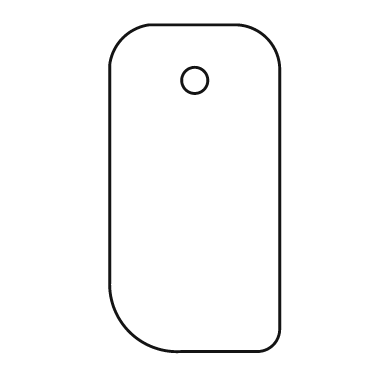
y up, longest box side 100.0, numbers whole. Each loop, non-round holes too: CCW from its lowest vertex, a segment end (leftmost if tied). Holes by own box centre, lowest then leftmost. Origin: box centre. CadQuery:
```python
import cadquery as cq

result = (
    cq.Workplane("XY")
    .moveTo(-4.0, -50.0)
    .lineTo(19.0, -50.0)
    .threePointArc((24.0, -48.0), (26.0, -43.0))
    .lineTo(26.0, 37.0)
    .threePointArc((22.0, 46.0), (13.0, 50.0))
    .lineTo(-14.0, 50.0)
    .threePointArc((-22.0, 46.0), (-26.0, 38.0))
    .lineTo(-26.0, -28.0)
    .threePointArc((-20.0, -44.0), (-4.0, -50.0))
    .close()
    .moveTo(0.0, 33.0)
    .circle(4.0)
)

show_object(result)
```